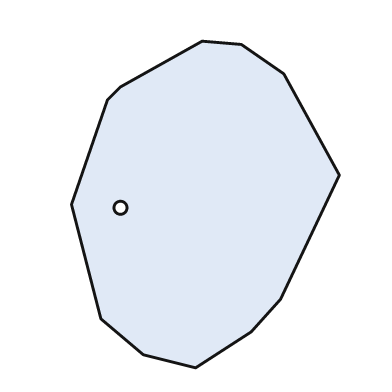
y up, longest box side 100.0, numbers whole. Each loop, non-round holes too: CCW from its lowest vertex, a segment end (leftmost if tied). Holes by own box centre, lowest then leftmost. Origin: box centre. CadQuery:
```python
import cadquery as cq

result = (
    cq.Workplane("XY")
    .moveTo(-3.0, -50.0)
    .lineTo(14.0, -39.0)
    .lineTo(23.0, -29.0)
    .lineTo(41.0, 9.0)
    .lineTo(24.0, 40.0)
    .lineTo(11.0, 49.0)
    .lineTo(-1.0, 50.0)
    .lineTo(-26.0, 36.0)
    .lineTo(-30.0, 32.0)
    .lineTo(-41.0, 0.0)
    .lineTo(-32.0, -35.0)
    .lineTo(-19.0, -46.0)
    .close()
    .moveTo(-26.0, -1.0)
    .circle(2.0)
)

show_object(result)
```